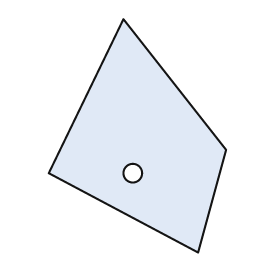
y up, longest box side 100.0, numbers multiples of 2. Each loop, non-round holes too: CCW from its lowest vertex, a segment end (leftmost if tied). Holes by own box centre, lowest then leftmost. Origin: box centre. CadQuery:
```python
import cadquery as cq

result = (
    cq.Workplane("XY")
    .moveTo(26.0, -50.0)
    .lineTo(38.0, -6.0)
    .lineTo(-6.0, 50.0)
    .lineTo(-38.0, -16.0)
    .close()
    .moveTo(-2.0, -16.0)
    .circle(4.0)
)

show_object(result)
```